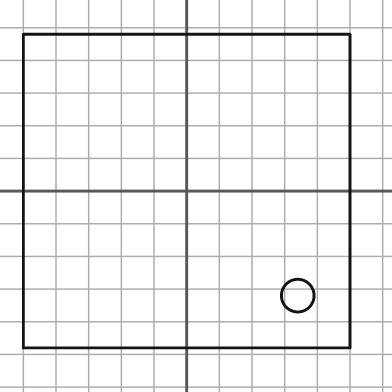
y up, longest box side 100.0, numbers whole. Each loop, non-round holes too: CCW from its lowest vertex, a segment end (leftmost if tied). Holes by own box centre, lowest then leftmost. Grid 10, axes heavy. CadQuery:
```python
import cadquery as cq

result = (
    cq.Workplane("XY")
    .moveTo(-50.0, -48.0)
    .lineTo(50.0, -48.0)
    .lineTo(50.0, 48.0)
    .lineTo(-50.0, 48.0)
    .close()
    .moveTo(34.0, -32.0)
    .circle(5.0)
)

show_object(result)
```